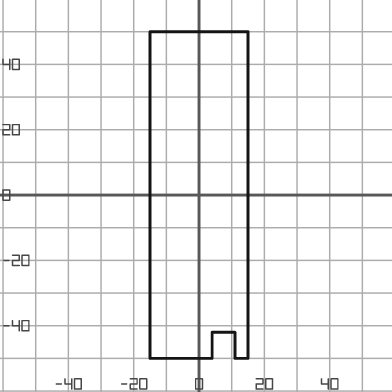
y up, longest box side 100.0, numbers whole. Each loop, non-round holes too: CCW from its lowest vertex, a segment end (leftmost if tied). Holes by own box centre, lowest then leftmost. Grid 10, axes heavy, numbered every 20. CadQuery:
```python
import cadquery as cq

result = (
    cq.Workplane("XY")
    .moveTo(-15.0, -50.0)
    .lineTo(4.0, -50.0)
    .lineTo(4.0, -42.0)
    .lineTo(11.0, -42.0)
    .lineTo(11.0, -50.0)
    .lineTo(15.0, -50.0)
    .lineTo(15.0, 50.0)
    .lineTo(-15.0, 50.0)
    .close()
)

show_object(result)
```